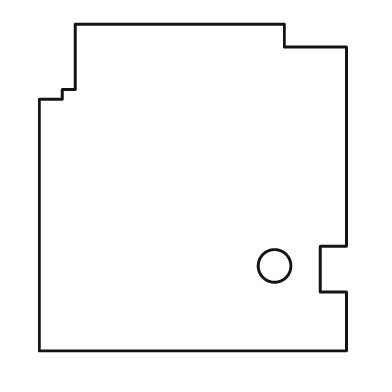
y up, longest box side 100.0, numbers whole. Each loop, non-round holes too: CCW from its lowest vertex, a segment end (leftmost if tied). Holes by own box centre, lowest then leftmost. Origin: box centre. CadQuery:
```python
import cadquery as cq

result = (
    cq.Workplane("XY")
    .moveTo(-47.0, -50.0)
    .lineTo(47.0, -50.0)
    .lineTo(47.0, -32.0)
    .lineTo(39.0, -32.0)
    .lineTo(39.0, -18.0)
    .lineTo(47.0, -18.0)
    .lineTo(47.0, 43.0)
    .lineTo(28.0, 43.0)
    .lineTo(28.0, 50.0)
    .lineTo(-36.0, 50.0)
    .lineTo(-36.0, 30.0)
    .lineTo(-40.0, 30.0)
    .lineTo(-40.0, 27.0)
    .lineTo(-47.0, 27.0)
    .close()
    .moveTo(25.0, -24.0)
    .circle(5.0)
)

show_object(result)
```